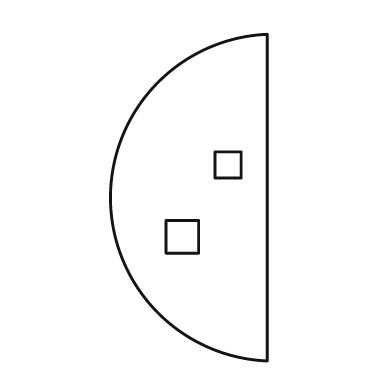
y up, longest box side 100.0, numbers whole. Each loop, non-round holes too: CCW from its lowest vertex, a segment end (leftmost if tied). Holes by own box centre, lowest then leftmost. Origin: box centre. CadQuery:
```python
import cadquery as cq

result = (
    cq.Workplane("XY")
    .moveTo(24.0, -50.0)
    .lineTo(24.0, 50.0)
    .threePointArc((-24.0, 0.0), (24.0, -50.0))
    .close()
    .moveTo(-7.0, -17.0)
    .lineTo(3.0, -17.0)
    .lineTo(3.0, -7.0)
    .lineTo(-7.0, -7.0)
    .close()
    .moveTo(8.0, 6.0)
    .lineTo(16.0, 6.0)
    .lineTo(16.0, 14.0)
    .lineTo(8.0, 14.0)
    .close()
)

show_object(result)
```